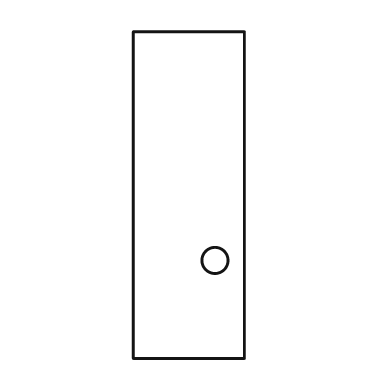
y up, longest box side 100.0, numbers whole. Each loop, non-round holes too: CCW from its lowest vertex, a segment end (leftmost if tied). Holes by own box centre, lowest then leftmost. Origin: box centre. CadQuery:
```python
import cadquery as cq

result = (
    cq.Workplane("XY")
    .moveTo(-17.0, -50.0)
    .lineTo(17.0, -50.0)
    .lineTo(17.0, 50.0)
    .lineTo(-17.0, 50.0)
    .close()
    .moveTo(8.0, -20.0)
    .circle(4.0)
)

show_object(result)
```